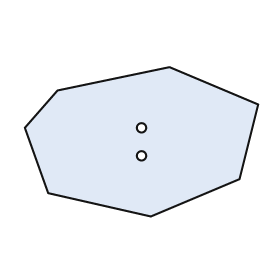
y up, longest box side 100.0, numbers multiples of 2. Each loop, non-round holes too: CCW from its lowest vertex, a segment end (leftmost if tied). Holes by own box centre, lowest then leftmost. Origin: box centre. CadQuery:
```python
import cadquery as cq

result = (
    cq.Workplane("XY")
    .moveTo(4.0, -32.0)
    .lineTo(42.0, -16.0)
    .lineTo(50.0, 16.0)
    .lineTo(12.0, 32.0)
    .lineTo(-36.0, 22.0)
    .lineTo(-50.0, 6.0)
    .lineTo(-40.0, -22.0)
    .close()
    .moveTo(0.0, -6.0)
    .circle(2.0)
    .moveTo(0.0, 6.0)
    .circle(2.0)
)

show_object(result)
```